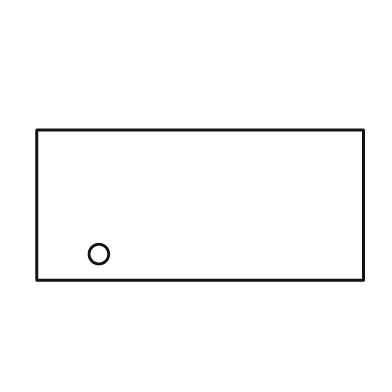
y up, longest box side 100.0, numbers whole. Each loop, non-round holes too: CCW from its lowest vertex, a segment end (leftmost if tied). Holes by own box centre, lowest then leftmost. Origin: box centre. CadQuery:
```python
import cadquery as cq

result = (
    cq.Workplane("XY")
    .moveTo(-50.0, -23.0)
    .lineTo(50.0, -23.0)
    .lineTo(50.0, 23.0)
    .lineTo(-50.0, 23.0)
    .close()
    .moveTo(-31.0, -15.0)
    .circle(3.0)
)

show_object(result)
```